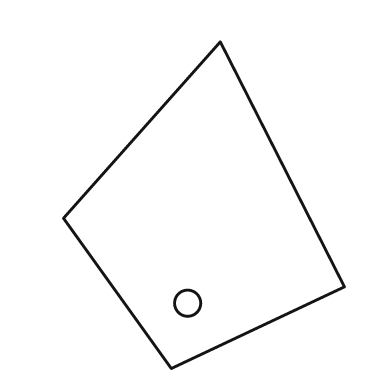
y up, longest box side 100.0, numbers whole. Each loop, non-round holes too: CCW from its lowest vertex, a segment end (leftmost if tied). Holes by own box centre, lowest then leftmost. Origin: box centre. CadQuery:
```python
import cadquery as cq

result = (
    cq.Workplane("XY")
    .moveTo(-10.0, -50.0)
    .lineTo(43.0, -25.0)
    .lineTo(5.0, 50.0)
    .lineTo(-43.0, -4.0)
    .close()
    .moveTo(-5.0, -30.0)
    .circle(4.0)
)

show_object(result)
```